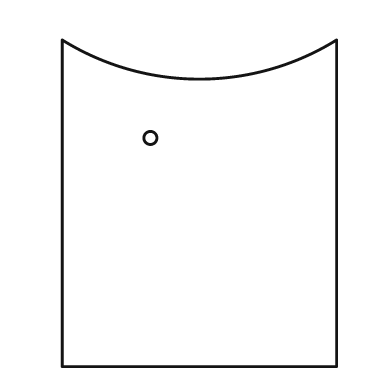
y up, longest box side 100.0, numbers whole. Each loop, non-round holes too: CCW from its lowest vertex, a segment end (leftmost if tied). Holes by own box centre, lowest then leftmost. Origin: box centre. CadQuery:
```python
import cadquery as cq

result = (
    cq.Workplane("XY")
    .moveTo(-42.0, -50.0)
    .lineTo(42.0, -50.0)
    .lineTo(42.0, 50.0)
    .threePointArc((0.0, 38.0), (-42.0, 50.0))
    .close()
    .moveTo(-15.0, 20.0)
    .circle(2.0)
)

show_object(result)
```